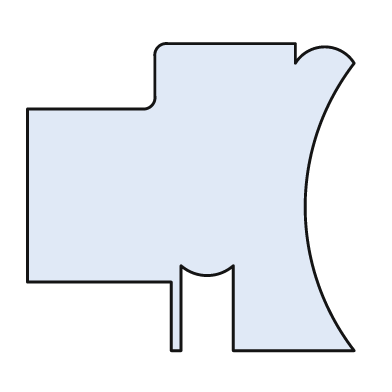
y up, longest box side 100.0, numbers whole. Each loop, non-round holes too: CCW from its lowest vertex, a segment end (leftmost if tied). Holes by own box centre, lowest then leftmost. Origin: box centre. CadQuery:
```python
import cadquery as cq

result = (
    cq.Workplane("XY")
    .moveTo(-6.0, -47.0)
    .lineTo(-3.0, -47.0)
    .lineTo(-3.0, -21.0)
    .threePointArc((5.0, -24.0), (13.0, -21.0))
    .lineTo(13.0, -47.0)
    .lineTo(50.0, -47.0)
    .threePointArc((35.0, -3.0), (50.0, 41.0))
    .threePointArc((41.0, 46.0), (32.0, 41.0))
    .lineTo(32.0, 47.0)
    .lineTo(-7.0, 47.0)
    .threePointArc((-10.0, 46.0), (-11.0, 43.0))
    .lineTo(-11.0, 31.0)
    .threePointArc((-12.0, 28.0), (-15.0, 27.0))
    .lineTo(-50.0, 27.0)
    .lineTo(-50.0, -26.0)
    .lineTo(-6.0, -26.0)
    .close()
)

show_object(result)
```